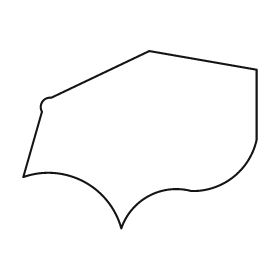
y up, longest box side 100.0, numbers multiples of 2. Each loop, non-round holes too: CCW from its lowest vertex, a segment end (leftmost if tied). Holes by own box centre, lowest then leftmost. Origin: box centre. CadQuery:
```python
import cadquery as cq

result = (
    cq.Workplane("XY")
    .moveTo(-8.0, -38.0)
    .threePointArc((4.0, -24.0), (22.0, -22.0))
    .threePointArc((40.0, -16.0), (50.0, 0.0))
    .lineTo(50.0, 30.0)
    .lineTo(4.0, 38.0)
    .lineTo(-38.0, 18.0)
    .threePointArc((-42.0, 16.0), (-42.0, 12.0))
    .lineTo(-50.0, -16.0)
    .threePointArc((-24.0, -18.0), (-8.0, -38.0))
    .close()
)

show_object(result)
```